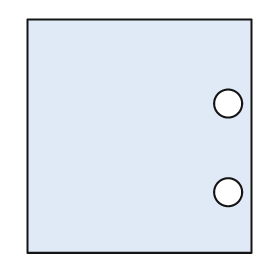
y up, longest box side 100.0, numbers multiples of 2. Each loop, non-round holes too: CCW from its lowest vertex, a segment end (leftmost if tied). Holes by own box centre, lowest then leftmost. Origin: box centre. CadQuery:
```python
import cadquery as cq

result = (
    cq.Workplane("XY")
    .moveTo(-48.0, -50.0)
    .lineTo(48.0, -50.0)
    .lineTo(48.0, 50.0)
    .lineTo(-48.0, 50.0)
    .close()
    .moveTo(38.0, -24.0)
    .circle(6.0)
    .moveTo(38.0, 14.0)
    .circle(6.0)
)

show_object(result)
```